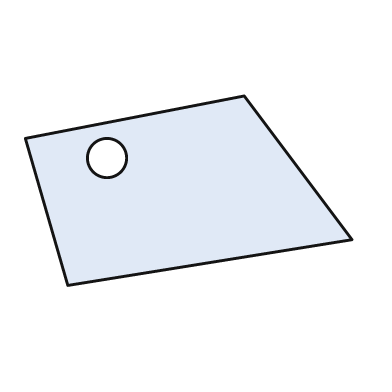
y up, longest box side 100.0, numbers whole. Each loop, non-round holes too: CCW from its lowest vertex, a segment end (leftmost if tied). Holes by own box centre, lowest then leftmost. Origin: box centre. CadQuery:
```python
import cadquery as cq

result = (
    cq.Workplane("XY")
    .moveTo(-37.0, -29.0)
    .lineTo(50.0, -15.0)
    .lineTo(17.0, 29.0)
    .lineTo(-50.0, 16.0)
    .close()
    .moveTo(-25.0, 10.0)
    .circle(6.0)
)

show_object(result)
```